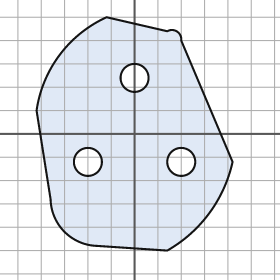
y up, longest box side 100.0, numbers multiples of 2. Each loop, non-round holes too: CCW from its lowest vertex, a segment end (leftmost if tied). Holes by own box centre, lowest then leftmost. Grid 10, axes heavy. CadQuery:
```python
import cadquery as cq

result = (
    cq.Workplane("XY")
    .moveTo(14.0, -50.0)
    .threePointArc((32.0, -34.0), (42.0, -12.0))
    .lineTo(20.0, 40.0)
    .threePointArc((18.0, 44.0), (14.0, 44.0))
    .lineTo(-12.0, 50.0)
    .threePointArc((-32.0, 34.0), (-42.0, 10.0))
    .lineTo(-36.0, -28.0)
    .threePointArc((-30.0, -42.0), (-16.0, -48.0))
    .close()
    .moveTo(-20.0, -12.0)
    .circle(6.0)
    .moveTo(20.0, -12.0)
    .circle(6.0)
    .moveTo(0.0, 24.0)
    .circle(6.0)
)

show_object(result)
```